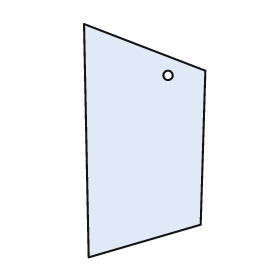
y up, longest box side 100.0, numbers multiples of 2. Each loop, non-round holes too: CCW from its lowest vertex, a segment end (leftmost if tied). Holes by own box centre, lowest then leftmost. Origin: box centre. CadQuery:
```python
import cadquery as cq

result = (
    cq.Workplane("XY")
    .moveTo(-24.0, -50.0)
    .lineTo(24.0, -36.0)
    .lineTo(26.0, 30.0)
    .lineTo(-26.0, 50.0)
    .close()
    .moveTo(10.0, 28.0)
    .circle(2.0)
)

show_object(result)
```